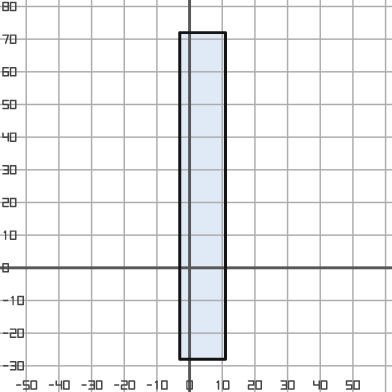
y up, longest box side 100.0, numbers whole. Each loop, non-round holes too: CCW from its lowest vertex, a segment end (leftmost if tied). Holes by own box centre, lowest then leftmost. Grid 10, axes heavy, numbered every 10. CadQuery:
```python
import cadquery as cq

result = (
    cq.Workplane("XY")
    .moveTo(-3.0, -28.0)
    .lineTo(11.0, -28.0)
    .lineTo(11.0, 72.0)
    .lineTo(-3.0, 72.0)
    .close()
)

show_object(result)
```